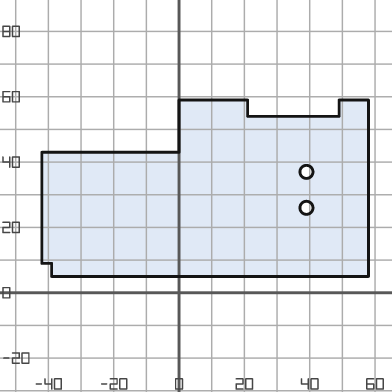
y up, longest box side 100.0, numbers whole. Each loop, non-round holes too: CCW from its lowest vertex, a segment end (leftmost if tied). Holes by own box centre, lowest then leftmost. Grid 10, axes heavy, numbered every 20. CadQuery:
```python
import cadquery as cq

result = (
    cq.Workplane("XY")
    .moveTo(-39.0, 5.0)
    .lineTo(58.0, 5.0)
    .lineTo(58.0, 59.0)
    .lineTo(49.0, 59.0)
    .lineTo(49.0, 54.0)
    .lineTo(21.0, 54.0)
    .lineTo(21.0, 59.0)
    .lineTo(0.0, 59.0)
    .lineTo(0.0, 43.0)
    .lineTo(-42.0, 43.0)
    .lineTo(-42.0, 9.0)
    .lineTo(-39.0, 9.0)
    .close()
    .moveTo(39.0, 26.0)
    .circle(2.0)
    .moveTo(39.0, 37.0)
    .circle(2.0)
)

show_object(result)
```